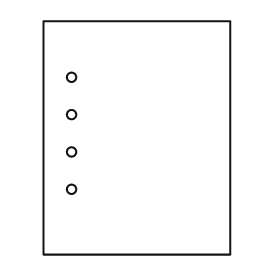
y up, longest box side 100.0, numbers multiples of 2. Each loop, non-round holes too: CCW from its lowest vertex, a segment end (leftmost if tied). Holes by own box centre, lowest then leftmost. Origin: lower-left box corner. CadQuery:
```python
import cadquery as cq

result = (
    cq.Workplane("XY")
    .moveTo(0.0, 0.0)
    .lineTo(80.0, 0.0)
    .lineTo(80.0, 100.0)
    .lineTo(0.0, 100.0)
    .close()
    .moveTo(12.0, 28.0)
    .circle(2.0)
    .moveTo(12.0, 44.0)
    .circle(2.0)
    .moveTo(12.0, 60.0)
    .circle(2.0)
    .moveTo(12.0, 76.0)
    .circle(2.0)
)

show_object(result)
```